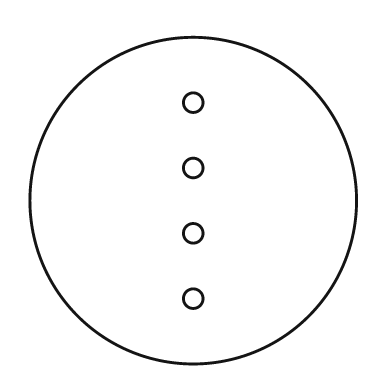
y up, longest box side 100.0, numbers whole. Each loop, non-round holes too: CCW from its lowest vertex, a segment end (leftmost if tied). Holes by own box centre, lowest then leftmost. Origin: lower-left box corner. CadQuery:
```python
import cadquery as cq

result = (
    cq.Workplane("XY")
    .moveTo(50.0, 50.0)
    .circle(50.0)
    .moveTo(50.0, 20.0)
    .circle(3.0)
    .moveTo(50.0, 40.0)
    .circle(3.0)
    .moveTo(50.0, 60.0)
    .circle(3.0)
    .moveTo(50.0, 80.0)
    .circle(3.0)
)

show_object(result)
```